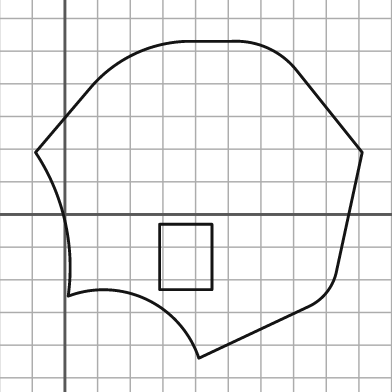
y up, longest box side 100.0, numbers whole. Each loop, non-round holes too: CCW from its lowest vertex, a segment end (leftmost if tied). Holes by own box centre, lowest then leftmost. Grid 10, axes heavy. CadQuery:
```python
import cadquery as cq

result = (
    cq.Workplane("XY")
    .moveTo(41.0, -44.0)
    .lineTo(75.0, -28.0)
    .threePointArc((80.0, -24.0), (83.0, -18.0))
    .lineTo(91.0, 19.0)
    .lineTo(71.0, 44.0)
    .threePointArc((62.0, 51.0), (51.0, 53.0))
    .lineTo(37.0, 53.0)
    .threePointArc((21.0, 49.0), (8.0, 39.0))
    .lineTo(-9.0, 19.0)
    .threePointArc((0.0, -2.0), (1.0, -25.0))
    .threePointArc((25.0, -26.0), (41.0, -44.0))
    .close()
    .moveTo(29.0, -23.0)
    .lineTo(45.0, -23.0)
    .lineTo(45.0, -3.0)
    .lineTo(29.0, -3.0)
    .close()
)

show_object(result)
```